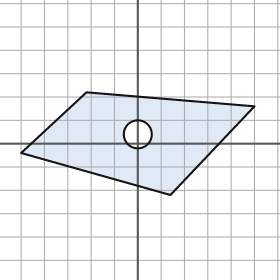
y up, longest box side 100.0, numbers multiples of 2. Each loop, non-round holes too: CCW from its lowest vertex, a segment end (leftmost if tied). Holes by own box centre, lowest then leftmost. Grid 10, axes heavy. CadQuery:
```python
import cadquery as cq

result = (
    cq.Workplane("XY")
    .moveTo(14.0, -22.0)
    .lineTo(50.0, 16.0)
    .lineTo(-22.0, 22.0)
    .lineTo(-50.0, -4.0)
    .close()
    .moveTo(0.0, 4.0)
    .circle(6.0)
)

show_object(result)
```